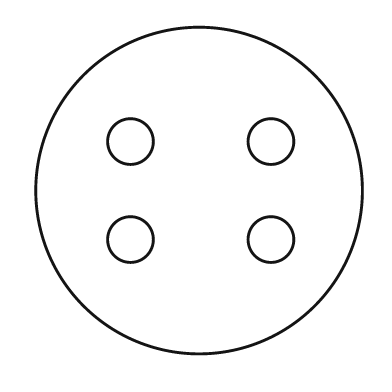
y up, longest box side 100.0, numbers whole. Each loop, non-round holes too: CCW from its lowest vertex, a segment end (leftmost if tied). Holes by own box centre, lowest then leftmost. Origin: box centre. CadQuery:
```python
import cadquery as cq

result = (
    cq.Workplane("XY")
    .moveTo(0.0, 0.0)
    .circle(50.0)
    .moveTo(-21.0, -15.0)
    .circle(7.0)
    .moveTo(22.0, -15.0)
    .circle(7.0)
    .moveTo(-21.0, 15.0)
    .circle(7.0)
    .moveTo(22.0, 15.0)
    .circle(7.0)
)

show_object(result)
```